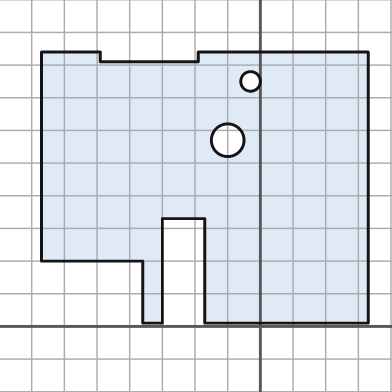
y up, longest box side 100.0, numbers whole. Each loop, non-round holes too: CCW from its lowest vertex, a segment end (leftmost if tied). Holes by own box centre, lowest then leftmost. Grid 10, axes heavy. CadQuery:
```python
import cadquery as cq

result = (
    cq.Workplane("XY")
    .moveTo(-36.0, 1.0)
    .lineTo(-30.0, 1.0)
    .lineTo(-30.0, 33.0)
    .lineTo(-17.0, 33.0)
    .lineTo(-17.0, 1.0)
    .lineTo(33.0, 1.0)
    .lineTo(33.0, 84.0)
    .lineTo(-19.0, 84.0)
    .lineTo(-19.0, 81.0)
    .lineTo(-49.0, 81.0)
    .lineTo(-49.0, 84.0)
    .lineTo(-67.0, 84.0)
    .lineTo(-67.0, 20.0)
    .lineTo(-36.0, 20.0)
    .close()
    .moveTo(-10.0, 57.0)
    .circle(5.0)
    .moveTo(-3.0, 75.0)
    .circle(3.0)
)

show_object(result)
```